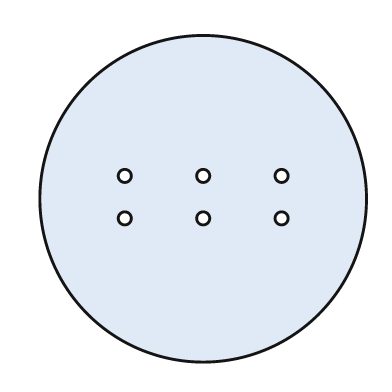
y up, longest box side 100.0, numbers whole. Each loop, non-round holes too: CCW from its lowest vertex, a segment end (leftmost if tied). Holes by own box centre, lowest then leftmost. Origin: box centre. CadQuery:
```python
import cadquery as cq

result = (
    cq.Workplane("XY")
    .moveTo(0.0, 0.0)
    .circle(50.0)
    .moveTo(-24.0, -6.0)
    .circle(2.0)
    .moveTo(0.0, -6.0)
    .circle(2.0)
    .moveTo(24.0, -6.0)
    .circle(2.0)
    .moveTo(-24.0, 7.0)
    .circle(2.0)
    .moveTo(0.0, 7.0)
    .circle(2.0)
    .moveTo(24.0, 7.0)
    .circle(2.0)
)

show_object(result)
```